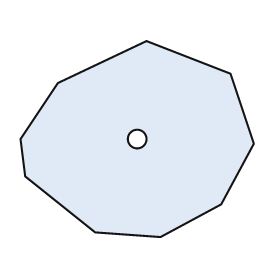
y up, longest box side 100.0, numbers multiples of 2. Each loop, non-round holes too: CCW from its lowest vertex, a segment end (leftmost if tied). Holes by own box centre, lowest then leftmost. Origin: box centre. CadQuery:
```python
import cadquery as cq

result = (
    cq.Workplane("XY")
    .moveTo(10.0, -42.0)
    .lineTo(36.0, -28.0)
    .lineTo(50.0, -2.0)
    .lineTo(40.0, 28.0)
    .lineTo(4.0, 42.0)
    .lineTo(-34.0, 24.0)
    .lineTo(-50.0, 0.0)
    .lineTo(-48.0, -16.0)
    .lineTo(-18.0, -40.0)
    .close()
    .moveTo(0.0, 0.0)
    .circle(4.0)
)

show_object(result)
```